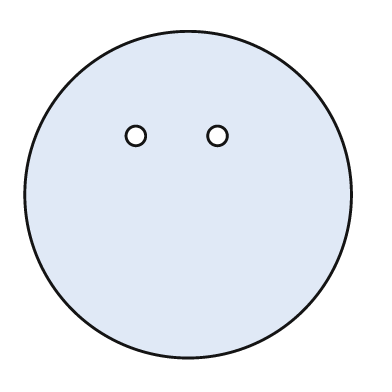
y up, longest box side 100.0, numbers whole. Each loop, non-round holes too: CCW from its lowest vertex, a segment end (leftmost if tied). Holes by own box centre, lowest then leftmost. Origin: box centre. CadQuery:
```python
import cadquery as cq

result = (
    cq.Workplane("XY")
    .moveTo(0.0, 0.0)
    .circle(50.0)
    .moveTo(-16.0, 18.0)
    .circle(3.0)
    .moveTo(9.0, 18.0)
    .circle(3.0)
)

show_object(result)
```